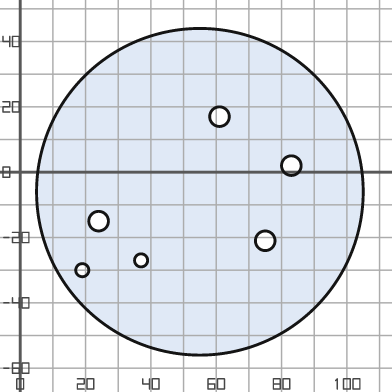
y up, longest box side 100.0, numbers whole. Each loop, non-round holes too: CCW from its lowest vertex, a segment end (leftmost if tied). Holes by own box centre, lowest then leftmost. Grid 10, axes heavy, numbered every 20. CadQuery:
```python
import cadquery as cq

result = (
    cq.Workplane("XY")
    .moveTo(55.0, -6.0)
    .circle(50.0)
    .moveTo(19.0, -30.0)
    .circle(2.0)
    .moveTo(37.0, -27.0)
    .circle(2.0)
    .moveTo(75.0, -21.0)
    .circle(3.0)
    .moveTo(24.0, -15.0)
    .circle(3.0)
    .moveTo(83.0, 2.0)
    .circle(3.0)
    .moveTo(61.0, 17.0)
    .circle(3.0)
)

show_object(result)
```